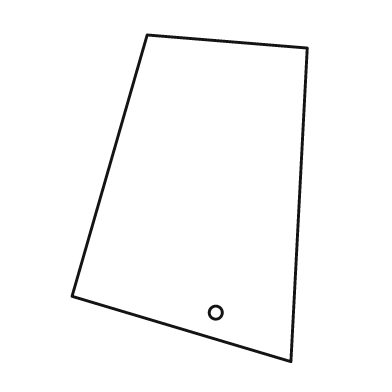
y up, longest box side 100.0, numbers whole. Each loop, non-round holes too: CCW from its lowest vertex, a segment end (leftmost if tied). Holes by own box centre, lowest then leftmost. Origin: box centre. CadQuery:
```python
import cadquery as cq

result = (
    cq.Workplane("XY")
    .moveTo(31.0, -50.0)
    .lineTo(36.0, 46.0)
    .lineTo(-13.0, 50.0)
    .lineTo(-36.0, -30.0)
    .close()
    .moveTo(8.0, -35.0)
    .circle(2.0)
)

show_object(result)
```